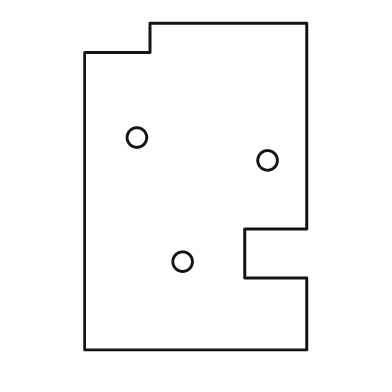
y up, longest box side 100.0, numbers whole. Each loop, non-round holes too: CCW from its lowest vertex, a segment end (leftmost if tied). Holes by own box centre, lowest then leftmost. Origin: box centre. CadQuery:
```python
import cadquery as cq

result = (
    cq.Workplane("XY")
    .moveTo(-34.0, -50.0)
    .lineTo(34.0, -50.0)
    .lineTo(34.0, -28.0)
    .lineTo(15.0, -28.0)
    .lineTo(15.0, -13.0)
    .lineTo(34.0, -13.0)
    .lineTo(34.0, 50.0)
    .lineTo(-14.0, 50.0)
    .lineTo(-14.0, 41.0)
    .lineTo(-34.0, 41.0)
    .close()
    .moveTo(-4.0, -23.0)
    .circle(3.0)
    .moveTo(22.0, 8.0)
    .circle(3.0)
    .moveTo(-18.0, 15.0)
    .circle(3.0)
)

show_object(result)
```